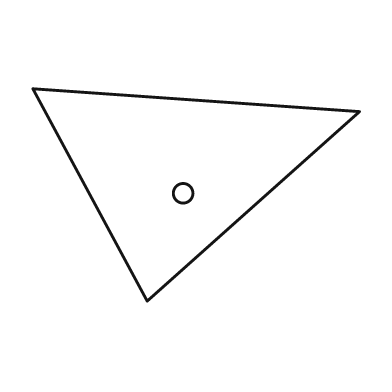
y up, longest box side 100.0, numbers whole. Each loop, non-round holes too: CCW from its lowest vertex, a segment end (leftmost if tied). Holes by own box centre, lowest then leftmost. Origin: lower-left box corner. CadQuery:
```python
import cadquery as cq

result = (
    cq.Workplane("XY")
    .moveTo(35.0, 0.0)
    .lineTo(100.0, 58.0)
    .lineTo(0.0, 65.0)
    .close()
    .moveTo(46.0, 33.0)
    .circle(3.0)
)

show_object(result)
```